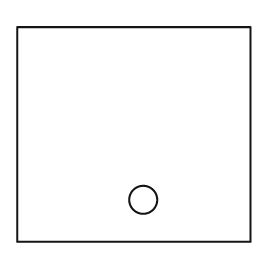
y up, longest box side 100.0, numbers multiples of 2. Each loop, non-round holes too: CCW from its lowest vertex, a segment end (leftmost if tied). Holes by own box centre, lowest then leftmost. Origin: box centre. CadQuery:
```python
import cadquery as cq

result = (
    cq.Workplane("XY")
    .moveTo(-50.0, -46.0)
    .lineTo(50.0, -46.0)
    .lineTo(50.0, 46.0)
    .lineTo(-50.0, 46.0)
    .close()
    .moveTo(4.0, -28.0)
    .circle(6.0)
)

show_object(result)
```